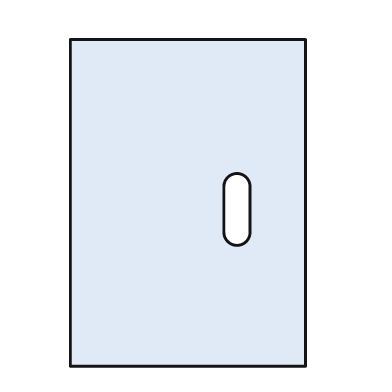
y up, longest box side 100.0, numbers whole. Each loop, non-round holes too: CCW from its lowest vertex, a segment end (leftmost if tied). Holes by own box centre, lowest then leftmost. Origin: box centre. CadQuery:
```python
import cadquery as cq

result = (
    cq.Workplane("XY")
    .moveTo(-36.0, -50.0)
    .lineTo(36.0, -50.0)
    .lineTo(36.0, 50.0)
    .lineTo(-36.0, 50.0)
    .close()
    .moveTo(11.0, -9.0)
    .threePointArc((15.0, -13.0), (19.0, -9.0))
    .lineTo(19.0, 5.0)
    .threePointArc((15.0, 9.0), (11.0, 5.0))
    .close()
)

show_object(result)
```